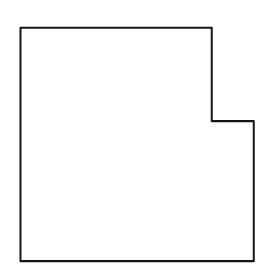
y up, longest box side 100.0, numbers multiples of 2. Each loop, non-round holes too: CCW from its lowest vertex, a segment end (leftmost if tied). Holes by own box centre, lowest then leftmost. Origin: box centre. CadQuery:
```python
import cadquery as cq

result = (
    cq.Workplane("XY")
    .moveTo(-50.0, -50.0)
    .lineTo(50.0, -50.0)
    .lineTo(50.0, 10.0)
    .lineTo(32.0, 10.0)
    .lineTo(32.0, 50.0)
    .lineTo(-50.0, 50.0)
    .close()
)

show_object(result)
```